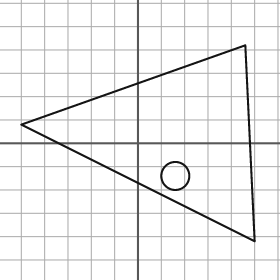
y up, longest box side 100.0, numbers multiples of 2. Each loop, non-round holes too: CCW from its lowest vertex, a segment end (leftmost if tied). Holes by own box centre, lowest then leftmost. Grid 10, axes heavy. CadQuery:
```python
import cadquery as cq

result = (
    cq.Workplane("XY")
    .moveTo(50.0, -42.0)
    .lineTo(46.0, 42.0)
    .lineTo(-50.0, 8.0)
    .close()
    .moveTo(16.0, -14.0)
    .circle(6.0)
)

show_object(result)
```